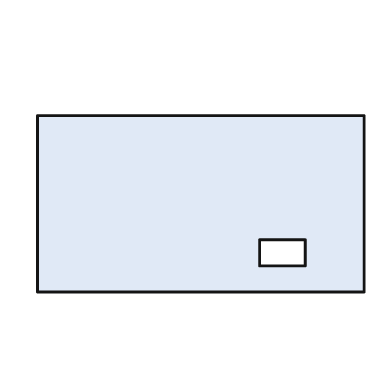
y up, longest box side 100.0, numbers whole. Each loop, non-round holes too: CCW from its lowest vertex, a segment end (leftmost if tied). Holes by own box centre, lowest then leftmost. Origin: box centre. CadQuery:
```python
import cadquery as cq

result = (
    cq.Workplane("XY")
    .moveTo(-50.0, -27.0)
    .lineTo(50.0, -27.0)
    .lineTo(50.0, 27.0)
    .lineTo(-50.0, 27.0)
    .close()
    .moveTo(18.0, -19.0)
    .lineTo(32.0, -19.0)
    .lineTo(32.0, -11.0)
    .lineTo(18.0, -11.0)
    .close()
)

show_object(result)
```